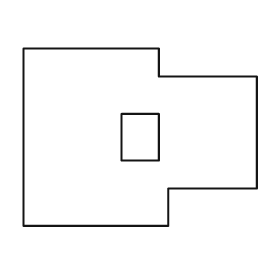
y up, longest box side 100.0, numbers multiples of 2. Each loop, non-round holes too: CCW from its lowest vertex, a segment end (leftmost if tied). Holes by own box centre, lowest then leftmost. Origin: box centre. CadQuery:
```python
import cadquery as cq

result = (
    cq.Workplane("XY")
    .moveTo(-50.0, -38.0)
    .lineTo(12.0, -38.0)
    .lineTo(12.0, -22.0)
    .lineTo(50.0, -22.0)
    .lineTo(50.0, 26.0)
    .lineTo(8.0, 26.0)
    .lineTo(8.0, 38.0)
    .lineTo(-50.0, 38.0)
    .close()
    .moveTo(-8.0, -10.0)
    .lineTo(8.0, -10.0)
    .lineTo(8.0, 10.0)
    .lineTo(-8.0, 10.0)
    .close()
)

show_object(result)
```